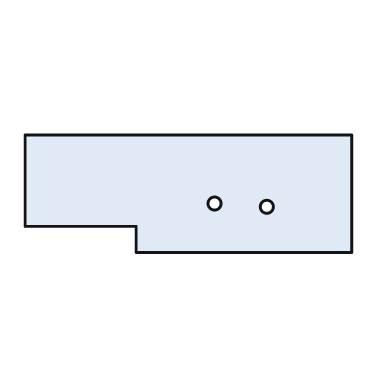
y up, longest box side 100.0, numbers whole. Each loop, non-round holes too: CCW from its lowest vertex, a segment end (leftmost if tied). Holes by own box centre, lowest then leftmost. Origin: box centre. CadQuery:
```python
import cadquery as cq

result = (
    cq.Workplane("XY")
    .moveTo(-16.0, -18.0)
    .lineTo(50.0, -18.0)
    .lineTo(50.0, 18.0)
    .lineTo(-50.0, 18.0)
    .lineTo(-50.0, -10.0)
    .lineTo(-16.0, -10.0)
    .close()
    .moveTo(24.0, -4.0)
    .circle(2.0)
    .moveTo(8.0, -3.0)
    .circle(2.0)
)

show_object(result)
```